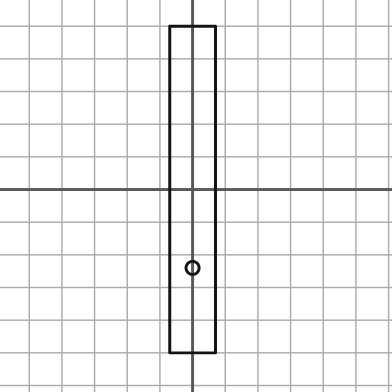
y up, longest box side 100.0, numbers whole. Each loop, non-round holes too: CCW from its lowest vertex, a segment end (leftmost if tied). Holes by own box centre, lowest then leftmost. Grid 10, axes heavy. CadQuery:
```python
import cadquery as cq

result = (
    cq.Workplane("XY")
    .moveTo(-7.0, -50.0)
    .lineTo(7.0, -50.0)
    .lineTo(7.0, 50.0)
    .lineTo(-7.0, 50.0)
    .close()
    .moveTo(0.0, -24.0)
    .circle(2.0)
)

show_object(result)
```